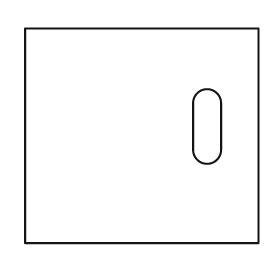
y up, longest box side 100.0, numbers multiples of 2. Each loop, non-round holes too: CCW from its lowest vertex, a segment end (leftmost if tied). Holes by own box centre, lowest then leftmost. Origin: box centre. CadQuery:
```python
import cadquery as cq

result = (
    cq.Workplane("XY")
    .moveTo(-50.0, -46.0)
    .lineTo(50.0, -46.0)
    .lineTo(50.0, 46.0)
    .lineTo(-50.0, 46.0)
    .close()
    .moveTo(22.0, -6.0)
    .threePointArc((28.0, -12.0), (34.0, -6.0))
    .lineTo(34.0, 14.0)
    .threePointArc((28.0, 20.0), (22.0, 14.0))
    .close()
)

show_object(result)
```